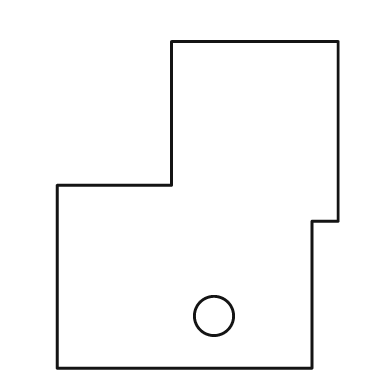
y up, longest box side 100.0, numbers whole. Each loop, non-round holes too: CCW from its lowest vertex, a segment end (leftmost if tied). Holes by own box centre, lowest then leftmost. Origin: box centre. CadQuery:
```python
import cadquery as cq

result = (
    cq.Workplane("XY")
    .moveTo(-43.0, -50.0)
    .lineTo(35.0, -50.0)
    .lineTo(35.0, -5.0)
    .lineTo(43.0, -5.0)
    .lineTo(43.0, 50.0)
    .lineTo(-8.0, 50.0)
    .lineTo(-8.0, 6.0)
    .lineTo(-43.0, 6.0)
    .close()
    .moveTo(5.0, -34.0)
    .circle(6.0)
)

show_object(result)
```